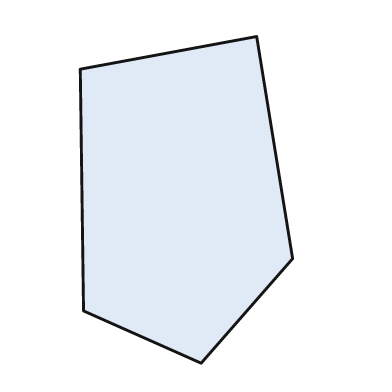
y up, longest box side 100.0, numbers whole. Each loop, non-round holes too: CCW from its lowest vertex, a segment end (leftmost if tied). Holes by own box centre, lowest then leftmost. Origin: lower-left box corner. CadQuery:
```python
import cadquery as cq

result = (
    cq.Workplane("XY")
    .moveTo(37.0, 0.0)
    .lineTo(65.0, 32.0)
    .lineTo(54.0, 100.0)
    .lineTo(0.0, 90.0)
    .lineTo(1.0, 16.0)
    .close()
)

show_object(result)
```